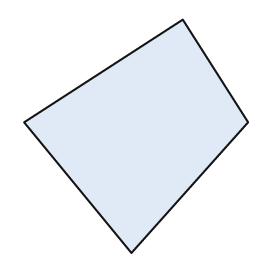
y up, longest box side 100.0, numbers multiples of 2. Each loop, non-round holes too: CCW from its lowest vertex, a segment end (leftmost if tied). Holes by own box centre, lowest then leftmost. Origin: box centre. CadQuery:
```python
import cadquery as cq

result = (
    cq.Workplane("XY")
    .moveTo(-2.0, -50.0)
    .lineTo(48.0, 6.0)
    .lineTo(20.0, 50.0)
    .lineTo(-48.0, 6.0)
    .close()
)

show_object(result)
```